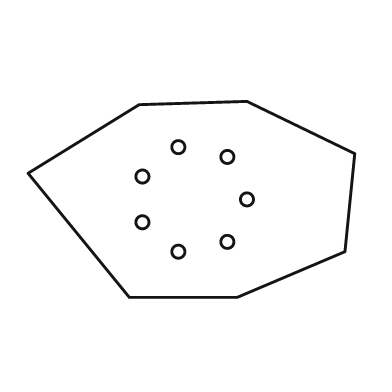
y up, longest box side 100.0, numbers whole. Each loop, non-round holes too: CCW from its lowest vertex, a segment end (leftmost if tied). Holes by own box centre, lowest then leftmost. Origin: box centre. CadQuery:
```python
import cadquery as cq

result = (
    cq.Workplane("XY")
    .moveTo(-19.0, -30.0)
    .lineTo(14.0, -30.0)
    .lineTo(47.0, -16.0)
    .lineTo(50.0, 14.0)
    .lineTo(17.0, 30.0)
    .lineTo(-16.0, 29.0)
    .lineTo(-50.0, 8.0)
    .close()
    .moveTo(-4.0, -16.0)
    .circle(2.0)
    .moveTo(11.0, -13.0)
    .circle(2.0)
    .moveTo(-15.0, -7.0)
    .circle(2.0)
    .moveTo(17.0, 0.0)
    .circle(2.0)
    .moveTo(-15.0, 7.0)
    .circle(2.0)
    .moveTo(11.0, 13.0)
    .circle(2.0)
    .moveTo(-4.0, 16.0)
    .circle(2.0)
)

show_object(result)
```